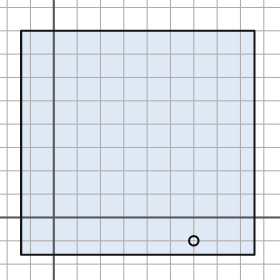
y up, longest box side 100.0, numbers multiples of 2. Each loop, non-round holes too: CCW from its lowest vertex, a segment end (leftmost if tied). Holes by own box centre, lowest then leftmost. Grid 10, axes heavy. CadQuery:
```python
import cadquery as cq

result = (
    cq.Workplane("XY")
    .moveTo(-14.0, -16.0)
    .lineTo(86.0, -16.0)
    .lineTo(86.0, 80.0)
    .lineTo(-14.0, 80.0)
    .close()
    .moveTo(60.0, -10.0)
    .circle(2.0)
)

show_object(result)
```